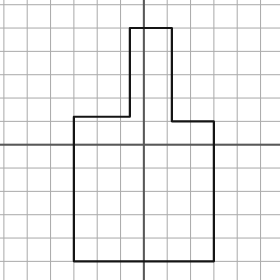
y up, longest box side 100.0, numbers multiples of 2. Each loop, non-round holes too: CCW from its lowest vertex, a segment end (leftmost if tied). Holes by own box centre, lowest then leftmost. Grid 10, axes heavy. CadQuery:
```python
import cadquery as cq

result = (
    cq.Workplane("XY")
    .moveTo(-30.0, -50.0)
    .lineTo(30.0, -50.0)
    .lineTo(30.0, 10.0)
    .lineTo(12.0, 10.0)
    .lineTo(12.0, 50.0)
    .lineTo(-6.0, 50.0)
    .lineTo(-6.0, 12.0)
    .lineTo(-30.0, 12.0)
    .close()
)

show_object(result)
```